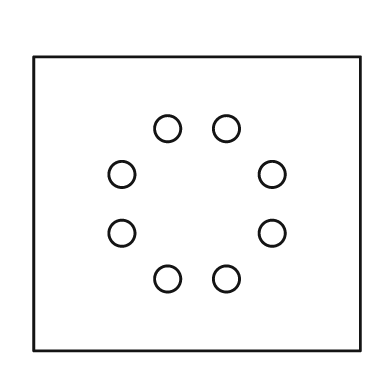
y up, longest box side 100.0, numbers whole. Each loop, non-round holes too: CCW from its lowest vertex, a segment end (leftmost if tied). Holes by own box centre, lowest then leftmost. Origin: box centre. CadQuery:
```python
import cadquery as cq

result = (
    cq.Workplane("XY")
    .moveTo(-50.0, -45.0)
    .lineTo(50.0, -45.0)
    .lineTo(50.0, 45.0)
    .lineTo(-50.0, 45.0)
    .close()
    .moveTo(-9.0, -23.0)
    .circle(4.0)
    .moveTo(9.0, -23.0)
    .circle(4.0)
    .moveTo(-23.0, -9.0)
    .circle(4.0)
    .moveTo(23.0, -9.0)
    .circle(4.0)
    .moveTo(-23.0, 9.0)
    .circle(4.0)
    .moveTo(23.0, 9.0)
    .circle(4.0)
    .moveTo(-9.0, 23.0)
    .circle(4.0)
    .moveTo(9.0, 23.0)
    .circle(4.0)
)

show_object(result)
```